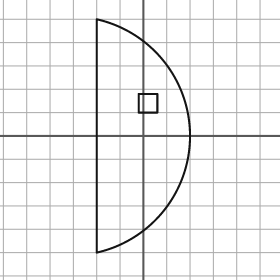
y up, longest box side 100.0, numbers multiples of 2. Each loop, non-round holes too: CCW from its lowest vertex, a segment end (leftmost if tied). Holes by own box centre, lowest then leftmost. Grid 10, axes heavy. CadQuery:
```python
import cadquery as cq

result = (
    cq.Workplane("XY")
    .moveTo(-20.0, -50.0)
    .threePointArc((20.0, 0.0), (-20.0, 50.0))
    .close()
    .moveTo(-2.0, 10.0)
    .lineTo(6.0, 10.0)
    .lineTo(6.0, 18.0)
    .lineTo(-2.0, 18.0)
    .close()
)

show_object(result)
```